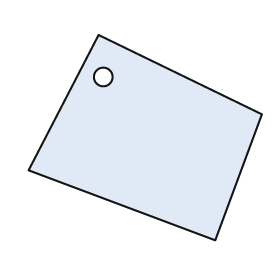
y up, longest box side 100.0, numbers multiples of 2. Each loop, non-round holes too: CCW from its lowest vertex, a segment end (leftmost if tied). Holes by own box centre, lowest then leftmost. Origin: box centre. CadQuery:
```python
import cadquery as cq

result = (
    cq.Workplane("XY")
    .moveTo(30.0, -44.0)
    .lineTo(50.0, 10.0)
    .lineTo(-20.0, 44.0)
    .lineTo(-50.0, -14.0)
    .close()
    .moveTo(-18.0, 26.0)
    .circle(4.0)
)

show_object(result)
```